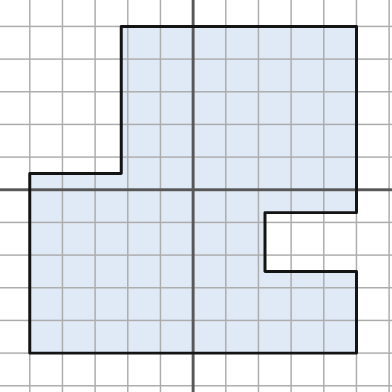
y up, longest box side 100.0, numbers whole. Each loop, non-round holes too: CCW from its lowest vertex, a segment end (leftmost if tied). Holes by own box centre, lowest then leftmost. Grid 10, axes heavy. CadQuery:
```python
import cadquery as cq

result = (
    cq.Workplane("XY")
    .moveTo(-50.0, -50.0)
    .lineTo(50.0, -50.0)
    .lineTo(50.0, -25.0)
    .lineTo(22.0, -25.0)
    .lineTo(22.0, -7.0)
    .lineTo(50.0, -7.0)
    .lineTo(50.0, 50.0)
    .lineTo(-22.0, 50.0)
    .lineTo(-22.0, 5.0)
    .lineTo(-50.0, 5.0)
    .close()
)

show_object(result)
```